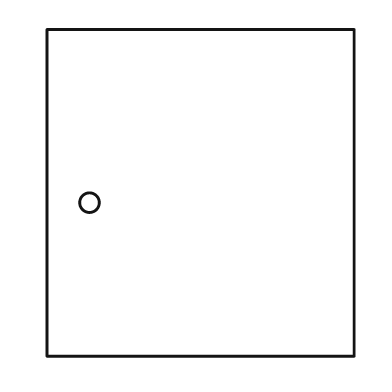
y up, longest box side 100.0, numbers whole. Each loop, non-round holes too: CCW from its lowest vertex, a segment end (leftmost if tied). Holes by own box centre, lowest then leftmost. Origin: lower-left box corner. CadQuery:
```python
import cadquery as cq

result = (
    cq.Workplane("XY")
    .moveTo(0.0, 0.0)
    .lineTo(94.0, 0.0)
    .lineTo(94.0, 100.0)
    .lineTo(0.0, 100.0)
    .close()
    .moveTo(13.0, 47.0)
    .circle(3.0)
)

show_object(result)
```